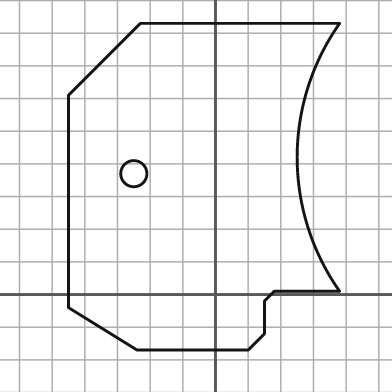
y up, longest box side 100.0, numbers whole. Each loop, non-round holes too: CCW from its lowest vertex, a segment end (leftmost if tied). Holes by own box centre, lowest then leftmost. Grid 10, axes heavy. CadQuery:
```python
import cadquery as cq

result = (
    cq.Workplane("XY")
    .moveTo(-24.0, -17.0)
    .lineTo(10.0, -17.0)
    .lineTo(15.0, -12.0)
    .lineTo(15.0, -2.0)
    .lineTo(18.0, 1.0)
    .lineTo(38.0, 1.0)
    .threePointArc((25.0, 42.0), (38.0, 83.0))
    .lineTo(-23.0, 83.0)
    .lineTo(-45.0, 61.0)
    .lineTo(-45.0, -4.0)
    .close()
    .moveTo(-25.0, 37.0)
    .circle(4.0)
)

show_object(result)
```